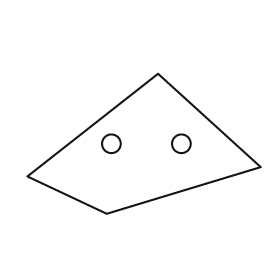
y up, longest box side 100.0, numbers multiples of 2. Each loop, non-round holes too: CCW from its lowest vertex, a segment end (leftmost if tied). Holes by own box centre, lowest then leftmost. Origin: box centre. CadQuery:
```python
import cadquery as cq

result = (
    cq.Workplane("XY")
    .moveTo(-16.0, -30.0)
    .lineTo(50.0, -10.0)
    .lineTo(6.0, 30.0)
    .lineTo(-50.0, -14.0)
    .close()
    .moveTo(-14.0, 0.0)
    .circle(4.0)
    .moveTo(16.0, 0.0)
    .circle(4.0)
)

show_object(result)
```